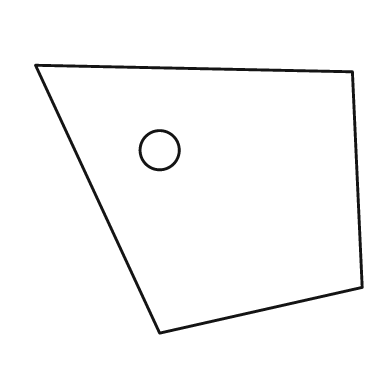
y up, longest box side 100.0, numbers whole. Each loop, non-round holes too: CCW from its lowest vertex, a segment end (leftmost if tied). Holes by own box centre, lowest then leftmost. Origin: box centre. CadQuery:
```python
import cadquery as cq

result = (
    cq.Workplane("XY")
    .moveTo(-12.0, -41.0)
    .lineTo(50.0, -27.0)
    .lineTo(47.0, 39.0)
    .lineTo(-50.0, 41.0)
    .close()
    .moveTo(-12.0, 15.0)
    .circle(6.0)
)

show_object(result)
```